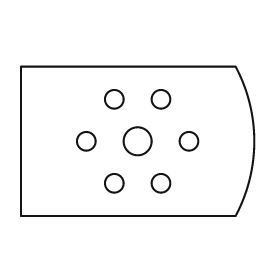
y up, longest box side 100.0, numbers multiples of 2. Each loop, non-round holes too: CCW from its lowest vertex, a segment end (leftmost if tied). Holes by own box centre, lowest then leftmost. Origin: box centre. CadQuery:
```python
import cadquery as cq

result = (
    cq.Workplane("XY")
    .moveTo(-50.0, -32.0)
    .lineTo(42.0, -32.0)
    .threePointArc((50.0, 0.0), (42.0, 32.0))
    .lineTo(-50.0, 32.0)
    .close()
    .moveTo(-10.0, -18.0)
    .circle(4.0)
    .moveTo(10.0, -18.0)
    .circle(4.0)
    .moveTo(-22.0, 0.0)
    .circle(4.0)
    .moveTo(0.0, 0.0)
    .circle(6.0)
    .moveTo(22.0, 0.0)
    .circle(4.0)
    .moveTo(-10.0, 18.0)
    .circle(4.0)
    .moveTo(10.0, 18.0)
    .circle(4.0)
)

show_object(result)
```